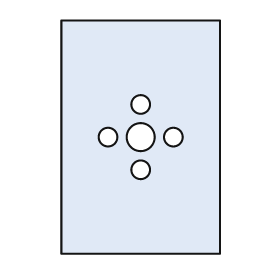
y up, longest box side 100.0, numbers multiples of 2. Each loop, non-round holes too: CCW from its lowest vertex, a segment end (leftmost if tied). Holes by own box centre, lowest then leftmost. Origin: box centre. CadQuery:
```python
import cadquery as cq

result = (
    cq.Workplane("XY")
    .moveTo(-34.0, -50.0)
    .lineTo(34.0, -50.0)
    .lineTo(34.0, 50.0)
    .lineTo(-34.0, 50.0)
    .close()
    .moveTo(0.0, -14.0)
    .circle(4.0)
    .moveTo(-14.0, 0.0)
    .circle(4.0)
    .moveTo(0.0, 0.0)
    .circle(6.0)
    .moveTo(14.0, 0.0)
    .circle(4.0)
    .moveTo(0.0, 14.0)
    .circle(4.0)
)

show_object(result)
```